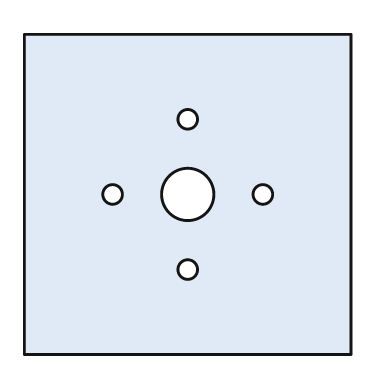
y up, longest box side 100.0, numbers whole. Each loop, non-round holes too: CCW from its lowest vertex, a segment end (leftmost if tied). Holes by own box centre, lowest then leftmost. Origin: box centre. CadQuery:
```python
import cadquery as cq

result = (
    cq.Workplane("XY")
    .moveTo(-50.0, -49.0)
    .lineTo(50.0, -49.0)
    .lineTo(50.0, 49.0)
    .lineTo(-50.0, 49.0)
    .close()
    .moveTo(0.0, -23.0)
    .circle(3.0)
    .moveTo(-23.0, 0.0)
    .circle(3.0)
    .moveTo(0.0, 0.0)
    .circle(8.0)
    .moveTo(23.0, 0.0)
    .circle(3.0)
    .moveTo(0.0, 23.0)
    .circle(3.0)
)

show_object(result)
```